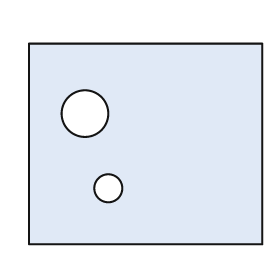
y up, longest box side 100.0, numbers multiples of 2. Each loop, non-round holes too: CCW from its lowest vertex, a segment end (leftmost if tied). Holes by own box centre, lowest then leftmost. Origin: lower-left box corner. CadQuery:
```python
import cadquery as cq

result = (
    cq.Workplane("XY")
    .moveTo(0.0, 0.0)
    .lineTo(100.0, 0.0)
    .lineTo(100.0, 86.0)
    .lineTo(0.0, 86.0)
    .close()
    .moveTo(34.0, 24.0)
    .circle(6.0)
    .moveTo(24.0, 56.0)
    .circle(10.0)
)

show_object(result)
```